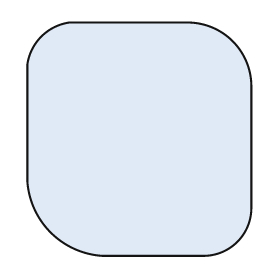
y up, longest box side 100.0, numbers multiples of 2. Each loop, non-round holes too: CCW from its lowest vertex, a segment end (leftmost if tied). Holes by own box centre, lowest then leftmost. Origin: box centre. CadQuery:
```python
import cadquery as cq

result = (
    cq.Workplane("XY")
    .moveTo(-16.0, -50.0)
    .lineTo(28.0, -50.0)
    .threePointArc((42.0, -44.0), (48.0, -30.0))
    .lineTo(48.0, 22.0)
    .threePointArc((40.0, 42.0), (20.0, 50.0))
    .lineTo(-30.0, 50.0)
    .threePointArc((-42.0, 44.0), (-48.0, 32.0))
    .lineTo(-48.0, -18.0)
    .threePointArc((-38.0, -40.0), (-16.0, -50.0))
    .close()
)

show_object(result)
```